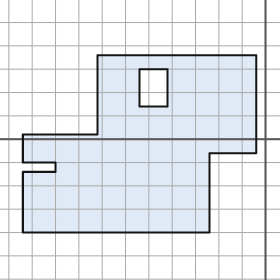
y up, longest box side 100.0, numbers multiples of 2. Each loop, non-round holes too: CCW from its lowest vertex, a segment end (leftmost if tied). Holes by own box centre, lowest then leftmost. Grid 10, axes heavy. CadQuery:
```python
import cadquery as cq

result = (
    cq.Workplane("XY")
    .moveTo(-104.0, -40.0)
    .lineTo(-24.0, -40.0)
    .lineTo(-24.0, -6.0)
    .lineTo(-4.0, -6.0)
    .lineTo(-4.0, 36.0)
    .lineTo(-72.0, 36.0)
    .lineTo(-72.0, 2.0)
    .lineTo(-104.0, 2.0)
    .lineTo(-104.0, -10.0)
    .lineTo(-90.0, -10.0)
    .lineTo(-90.0, -14.0)
    .lineTo(-104.0, -14.0)
    .close()
    .moveTo(-54.0, 14.0)
    .lineTo(-42.0, 14.0)
    .lineTo(-42.0, 30.0)
    .lineTo(-54.0, 30.0)
    .close()
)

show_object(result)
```